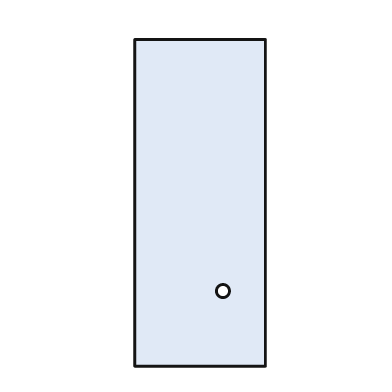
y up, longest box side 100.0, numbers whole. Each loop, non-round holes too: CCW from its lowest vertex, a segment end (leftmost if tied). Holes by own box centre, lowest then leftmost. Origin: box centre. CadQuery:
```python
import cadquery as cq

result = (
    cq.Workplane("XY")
    .moveTo(-20.0, -50.0)
    .lineTo(20.0, -50.0)
    .lineTo(20.0, 50.0)
    .lineTo(-20.0, 50.0)
    .close()
    .moveTo(7.0, -27.0)
    .circle(2.0)
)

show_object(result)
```